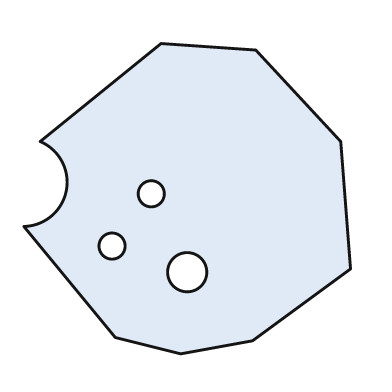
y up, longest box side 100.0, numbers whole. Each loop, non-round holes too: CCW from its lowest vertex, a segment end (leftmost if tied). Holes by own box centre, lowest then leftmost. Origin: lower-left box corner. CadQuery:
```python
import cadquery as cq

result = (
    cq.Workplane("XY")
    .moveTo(48.0, 0.0)
    .lineTo(70.0, 4.0)
    .lineTo(100.0, 26.0)
    .lineTo(97.0, 65.0)
    .lineTo(71.0, 93.0)
    .lineTo(42.0, 95.0)
    .lineTo(5.0, 65.0)
    .threePointArc((13.0, 50.0), (0.0, 39.0))
    .lineTo(28.0, 5.0)
    .close()
    .moveTo(50.0, 25.0)
    .circle(6.0)
    .moveTo(27.0, 33.0)
    .circle(4.0)
    .moveTo(39.0, 49.0)
    .circle(4.0)
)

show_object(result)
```